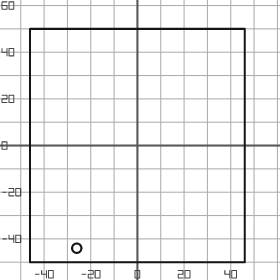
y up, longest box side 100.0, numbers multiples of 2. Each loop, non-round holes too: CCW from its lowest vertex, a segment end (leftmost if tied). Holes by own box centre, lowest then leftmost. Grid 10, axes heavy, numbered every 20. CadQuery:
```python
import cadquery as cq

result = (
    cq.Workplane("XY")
    .moveTo(-46.0, -50.0)
    .lineTo(46.0, -50.0)
    .lineTo(46.0, 50.0)
    .lineTo(-46.0, 50.0)
    .close()
    .moveTo(-26.0, -44.0)
    .circle(2.0)
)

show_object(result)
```